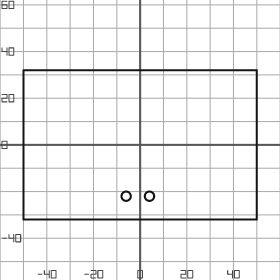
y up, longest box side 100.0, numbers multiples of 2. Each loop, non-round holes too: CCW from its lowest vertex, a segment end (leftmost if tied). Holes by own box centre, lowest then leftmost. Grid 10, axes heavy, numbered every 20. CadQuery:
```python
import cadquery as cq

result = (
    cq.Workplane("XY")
    .moveTo(-50.0, -32.0)
    .lineTo(50.0, -32.0)
    .lineTo(50.0, 32.0)
    .lineTo(-50.0, 32.0)
    .close()
    .moveTo(-6.0, -22.0)
    .circle(2.0)
    .moveTo(4.0, -22.0)
    .circle(2.0)
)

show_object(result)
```